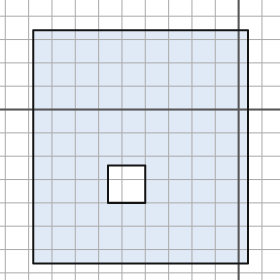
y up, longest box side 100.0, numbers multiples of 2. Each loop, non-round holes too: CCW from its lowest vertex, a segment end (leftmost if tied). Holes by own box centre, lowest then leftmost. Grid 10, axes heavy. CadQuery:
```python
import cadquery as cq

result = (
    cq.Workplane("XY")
    .moveTo(-88.0, -66.0)
    .lineTo(4.0, -66.0)
    .lineTo(4.0, 34.0)
    .lineTo(-88.0, 34.0)
    .close()
    .moveTo(-56.0, -40.0)
    .lineTo(-40.0, -40.0)
    .lineTo(-40.0, -24.0)
    .lineTo(-56.0, -24.0)
    .close()
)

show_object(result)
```